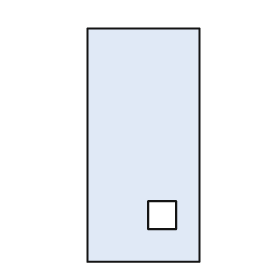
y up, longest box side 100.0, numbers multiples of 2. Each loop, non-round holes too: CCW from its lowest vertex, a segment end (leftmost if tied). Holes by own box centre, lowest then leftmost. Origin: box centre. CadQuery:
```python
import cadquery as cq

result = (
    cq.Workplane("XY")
    .moveTo(-24.0, -50.0)
    .lineTo(24.0, -50.0)
    .lineTo(24.0, 50.0)
    .lineTo(-24.0, 50.0)
    .close()
    .moveTo(2.0, -36.0)
    .lineTo(14.0, -36.0)
    .lineTo(14.0, -24.0)
    .lineTo(2.0, -24.0)
    .close()
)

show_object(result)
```